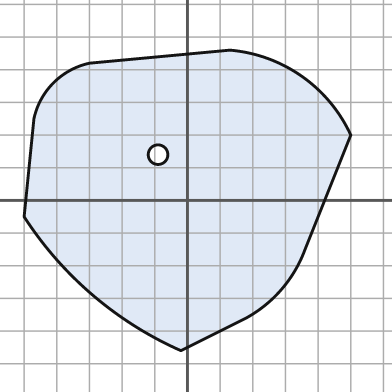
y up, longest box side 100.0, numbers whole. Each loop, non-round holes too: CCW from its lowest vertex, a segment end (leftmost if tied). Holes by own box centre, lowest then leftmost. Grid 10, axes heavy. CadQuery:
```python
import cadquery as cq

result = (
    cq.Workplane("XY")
    .moveTo(-2.0, -46.0)
    .lineTo(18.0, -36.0)
    .threePointArc((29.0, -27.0), (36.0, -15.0))
    .lineTo(50.0, 20.0)
    .threePointArc((35.0, 38.0), (13.0, 46.0))
    .lineTo(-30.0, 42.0)
    .threePointArc((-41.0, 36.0), (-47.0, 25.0))
    .lineTo(-50.0, -5.0)
    .threePointArc((-29.0, -29.0), (-2.0, -46.0))
    .close()
    .moveTo(-9.0, 14.0)
    .circle(3.0)
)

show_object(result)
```